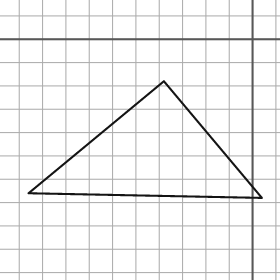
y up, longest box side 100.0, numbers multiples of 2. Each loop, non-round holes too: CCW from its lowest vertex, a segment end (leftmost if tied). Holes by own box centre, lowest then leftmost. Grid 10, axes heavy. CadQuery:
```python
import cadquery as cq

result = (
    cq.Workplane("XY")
    .moveTo(4.0, -68.0)
    .lineTo(-38.0, -18.0)
    .lineTo(-96.0, -66.0)
    .close()
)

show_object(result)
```